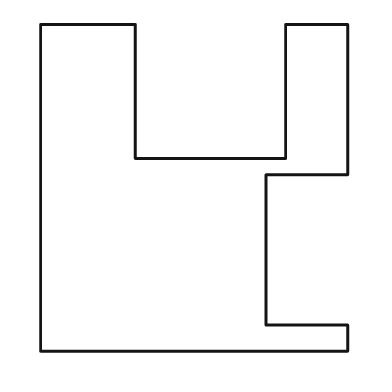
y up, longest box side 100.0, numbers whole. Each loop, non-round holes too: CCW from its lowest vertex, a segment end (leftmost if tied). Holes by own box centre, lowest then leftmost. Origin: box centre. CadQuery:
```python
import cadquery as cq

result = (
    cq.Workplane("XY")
    .moveTo(-47.0, -50.0)
    .lineTo(47.0, -50.0)
    .lineTo(47.0, -42.0)
    .lineTo(22.0, -42.0)
    .lineTo(22.0, 4.0)
    .lineTo(47.0, 4.0)
    .lineTo(47.0, 50.0)
    .lineTo(28.0, 50.0)
    .lineTo(28.0, 9.0)
    .lineTo(-18.0, 9.0)
    .lineTo(-18.0, 50.0)
    .lineTo(-47.0, 50.0)
    .close()
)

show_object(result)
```